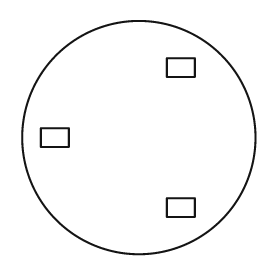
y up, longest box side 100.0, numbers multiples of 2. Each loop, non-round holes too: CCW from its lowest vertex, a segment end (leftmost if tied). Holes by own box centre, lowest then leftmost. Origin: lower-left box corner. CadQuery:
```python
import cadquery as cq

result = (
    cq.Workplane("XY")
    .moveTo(50.0, 50.0)
    .circle(50.0)
    .moveTo(62.0, 16.0)
    .lineTo(74.0, 16.0)
    .lineTo(74.0, 24.0)
    .lineTo(62.0, 24.0)
    .close()
    .moveTo(8.0, 46.0)
    .lineTo(20.0, 46.0)
    .lineTo(20.0, 54.0)
    .lineTo(8.0, 54.0)
    .close()
    .moveTo(62.0, 76.0)
    .lineTo(74.0, 76.0)
    .lineTo(74.0, 84.0)
    .lineTo(62.0, 84.0)
    .close()
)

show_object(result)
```